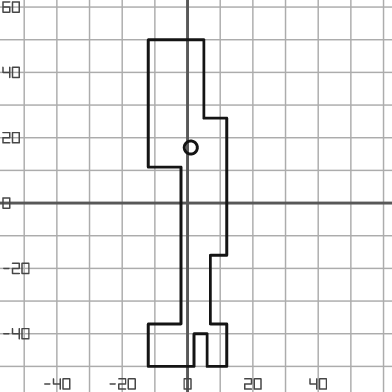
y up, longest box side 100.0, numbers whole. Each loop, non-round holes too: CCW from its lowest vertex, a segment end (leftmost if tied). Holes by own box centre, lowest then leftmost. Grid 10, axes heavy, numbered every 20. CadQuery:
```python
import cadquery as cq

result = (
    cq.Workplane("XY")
    .moveTo(-12.0, -50.0)
    .lineTo(2.0, -50.0)
    .lineTo(2.0, -40.0)
    .lineTo(6.0, -40.0)
    .lineTo(6.0, -50.0)
    .lineTo(12.0, -50.0)
    .lineTo(12.0, -37.0)
    .lineTo(7.0, -37.0)
    .lineTo(7.0, -16.0)
    .lineTo(12.0, -16.0)
    .lineTo(12.0, 26.0)
    .lineTo(5.0, 26.0)
    .lineTo(5.0, 50.0)
    .lineTo(-12.0, 50.0)
    .lineTo(-12.0, 11.0)
    .lineTo(-2.0, 11.0)
    .lineTo(-2.0, -37.0)
    .lineTo(-12.0, -37.0)
    .close()
    .moveTo(1.0, 17.0)
    .circle(2.0)
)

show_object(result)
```